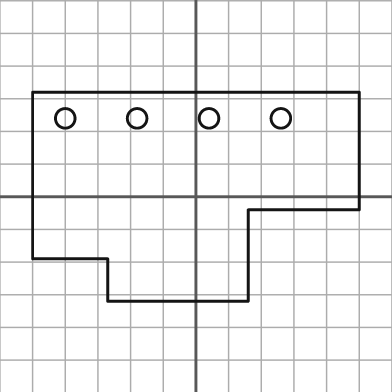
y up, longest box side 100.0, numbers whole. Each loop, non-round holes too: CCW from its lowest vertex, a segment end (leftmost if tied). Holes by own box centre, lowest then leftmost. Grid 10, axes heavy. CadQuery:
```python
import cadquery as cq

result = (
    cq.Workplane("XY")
    .moveTo(-27.0, -32.0)
    .lineTo(16.0, -32.0)
    .lineTo(16.0, -4.0)
    .lineTo(50.0, -4.0)
    .lineTo(50.0, 32.0)
    .lineTo(-50.0, 32.0)
    .lineTo(-50.0, -19.0)
    .lineTo(-27.0, -19.0)
    .close()
    .moveTo(-40.0, 24.0)
    .circle(3.0)
    .moveTo(-18.0, 24.0)
    .circle(3.0)
    .moveTo(4.0, 24.0)
    .circle(3.0)
    .moveTo(26.0, 24.0)
    .circle(3.0)
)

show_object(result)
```